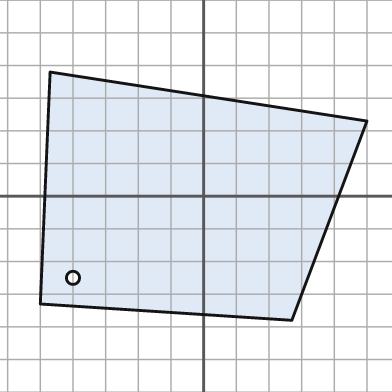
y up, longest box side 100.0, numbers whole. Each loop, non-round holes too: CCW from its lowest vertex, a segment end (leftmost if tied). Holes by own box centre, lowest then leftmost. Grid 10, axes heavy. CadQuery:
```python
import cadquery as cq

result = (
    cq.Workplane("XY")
    .moveTo(27.0, -38.0)
    .lineTo(50.0, 23.0)
    .lineTo(-47.0, 38.0)
    .lineTo(-50.0, -33.0)
    .close()
    .moveTo(-40.0, -25.0)
    .circle(2.0)
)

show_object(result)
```